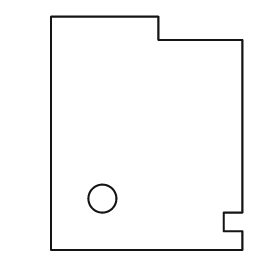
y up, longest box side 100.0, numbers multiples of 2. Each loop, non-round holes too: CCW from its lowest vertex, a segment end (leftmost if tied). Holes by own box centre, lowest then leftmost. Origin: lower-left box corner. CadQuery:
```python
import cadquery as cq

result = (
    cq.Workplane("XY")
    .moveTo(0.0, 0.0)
    .lineTo(82.0, 0.0)
    .lineTo(82.0, 8.0)
    .lineTo(74.0, 8.0)
    .lineTo(74.0, 16.0)
    .lineTo(82.0, 16.0)
    .lineTo(82.0, 90.0)
    .lineTo(46.0, 90.0)
    .lineTo(46.0, 100.0)
    .lineTo(0.0, 100.0)
    .close()
    .moveTo(22.0, 22.0)
    .circle(6.0)
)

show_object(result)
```